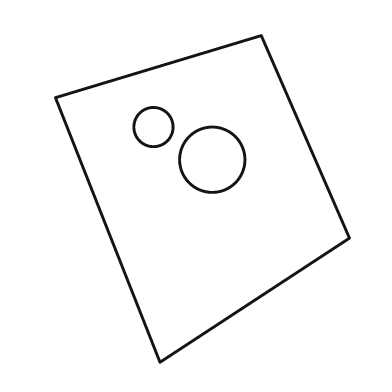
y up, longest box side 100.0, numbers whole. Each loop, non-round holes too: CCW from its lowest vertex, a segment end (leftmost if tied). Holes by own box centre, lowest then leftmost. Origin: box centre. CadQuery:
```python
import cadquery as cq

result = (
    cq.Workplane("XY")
    .moveTo(-13.0, -50.0)
    .lineTo(45.0, -12.0)
    .lineTo(18.0, 50.0)
    .lineTo(-45.0, 31.0)
    .close()
    .moveTo(3.0, 12.0)
    .circle(10.0)
    .moveTo(-15.0, 22.0)
    .circle(6.0)
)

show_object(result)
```